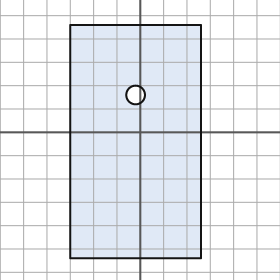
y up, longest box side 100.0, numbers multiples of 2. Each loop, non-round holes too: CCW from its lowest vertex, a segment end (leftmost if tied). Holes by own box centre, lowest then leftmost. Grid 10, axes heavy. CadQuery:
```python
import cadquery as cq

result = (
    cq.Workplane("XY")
    .moveTo(-30.0, -54.0)
    .lineTo(26.0, -54.0)
    .lineTo(26.0, 46.0)
    .lineTo(-30.0, 46.0)
    .close()
    .moveTo(-2.0, 16.0)
    .circle(4.0)
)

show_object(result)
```